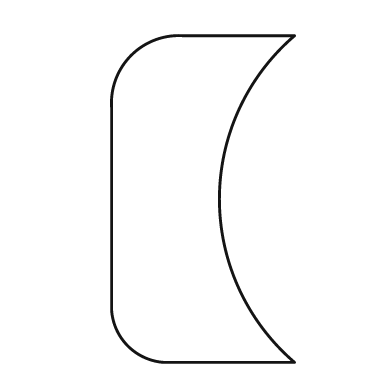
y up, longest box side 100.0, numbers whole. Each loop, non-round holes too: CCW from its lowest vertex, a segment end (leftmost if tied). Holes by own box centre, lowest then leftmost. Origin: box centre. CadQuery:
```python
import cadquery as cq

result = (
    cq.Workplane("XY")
    .moveTo(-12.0, -50.0)
    .lineTo(28.0, -50.0)
    .threePointArc((5.0, 0.0), (28.0, 50.0))
    .lineTo(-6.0, 50.0)
    .threePointArc((-22.0, 44.0), (-28.0, 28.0))
    .lineTo(-28.0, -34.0)
    .threePointArc((-23.0, -45.0), (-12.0, -50.0))
    .close()
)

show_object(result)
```